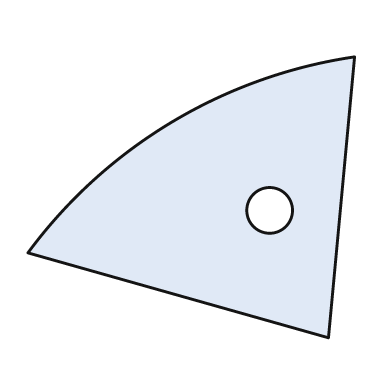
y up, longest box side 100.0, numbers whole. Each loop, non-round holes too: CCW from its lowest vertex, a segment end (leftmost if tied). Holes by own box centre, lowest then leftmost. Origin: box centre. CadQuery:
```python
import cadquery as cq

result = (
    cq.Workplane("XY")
    .moveTo(42.0, -43.0)
    .lineTo(50.0, 43.0)
    .threePointArc((-6.0, 23.0), (-50.0, -17.0))
    .close()
    .moveTo(24.0, -4.0)
    .circle(7.0)
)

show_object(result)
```